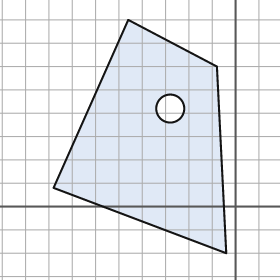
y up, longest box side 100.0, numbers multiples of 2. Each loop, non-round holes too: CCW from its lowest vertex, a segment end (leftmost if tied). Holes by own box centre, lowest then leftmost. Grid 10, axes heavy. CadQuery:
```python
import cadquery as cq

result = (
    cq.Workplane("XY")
    .moveTo(-4.0, -20.0)
    .lineTo(-8.0, 60.0)
    .lineTo(-46.0, 80.0)
    .lineTo(-78.0, 8.0)
    .close()
    .moveTo(-28.0, 42.0)
    .circle(6.0)
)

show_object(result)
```